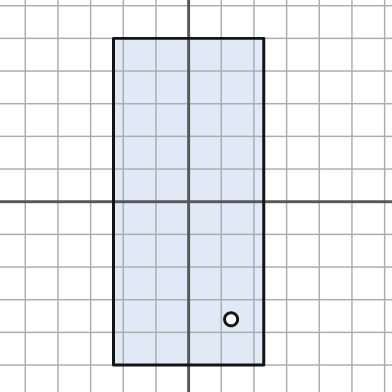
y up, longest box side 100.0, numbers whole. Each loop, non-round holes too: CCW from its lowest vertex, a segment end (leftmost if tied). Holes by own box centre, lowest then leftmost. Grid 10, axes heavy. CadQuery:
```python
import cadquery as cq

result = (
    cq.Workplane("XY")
    .moveTo(-23.0, -50.0)
    .lineTo(23.0, -50.0)
    .lineTo(23.0, 50.0)
    .lineTo(-23.0, 50.0)
    .close()
    .moveTo(13.0, -36.0)
    .circle(2.0)
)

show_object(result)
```